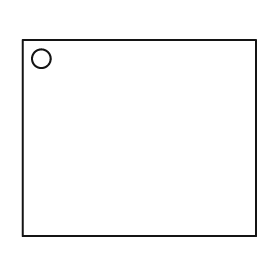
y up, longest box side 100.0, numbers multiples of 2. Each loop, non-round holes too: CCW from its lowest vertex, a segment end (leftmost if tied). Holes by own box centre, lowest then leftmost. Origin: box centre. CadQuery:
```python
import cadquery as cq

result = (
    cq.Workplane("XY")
    .moveTo(-50.0, -42.0)
    .lineTo(50.0, -42.0)
    .lineTo(50.0, 42.0)
    .lineTo(-50.0, 42.0)
    .close()
    .moveTo(-42.0, 34.0)
    .circle(4.0)
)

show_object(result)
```